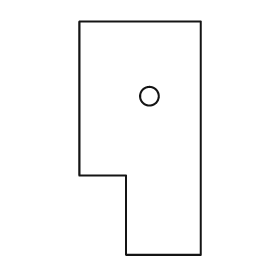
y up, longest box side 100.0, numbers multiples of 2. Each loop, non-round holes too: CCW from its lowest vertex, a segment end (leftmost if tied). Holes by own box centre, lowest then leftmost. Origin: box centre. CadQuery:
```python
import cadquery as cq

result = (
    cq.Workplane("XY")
    .moveTo(-6.0, -50.0)
    .lineTo(26.0, -50.0)
    .lineTo(26.0, 50.0)
    .lineTo(-26.0, 50.0)
    .lineTo(-26.0, -16.0)
    .lineTo(-6.0, -16.0)
    .close()
    .moveTo(4.0, 18.0)
    .circle(4.0)
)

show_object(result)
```